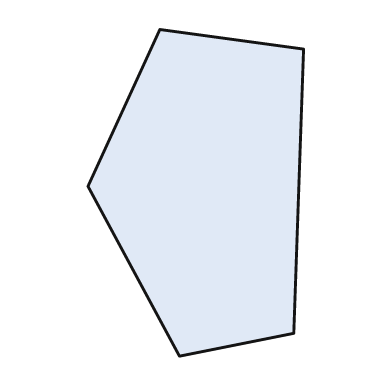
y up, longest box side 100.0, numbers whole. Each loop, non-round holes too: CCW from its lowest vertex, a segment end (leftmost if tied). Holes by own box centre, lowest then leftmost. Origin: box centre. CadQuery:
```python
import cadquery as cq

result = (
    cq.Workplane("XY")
    .moveTo(-5.0, -50.0)
    .lineTo(30.0, -43.0)
    .lineTo(33.0, 44.0)
    .lineTo(-11.0, 50.0)
    .lineTo(-33.0, 2.0)
    .close()
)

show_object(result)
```